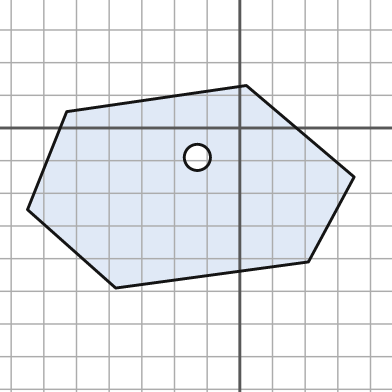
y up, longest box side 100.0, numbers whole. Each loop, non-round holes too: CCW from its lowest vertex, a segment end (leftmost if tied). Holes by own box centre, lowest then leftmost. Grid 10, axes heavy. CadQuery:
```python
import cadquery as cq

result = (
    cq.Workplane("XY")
    .moveTo(-38.0, -49.0)
    .lineTo(21.0, -41.0)
    .lineTo(35.0, -15.0)
    .lineTo(2.0, 13.0)
    .lineTo(-53.0, 5.0)
    .lineTo(-65.0, -25.0)
    .close()
    .moveTo(-13.0, -9.0)
    .circle(4.0)
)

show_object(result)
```